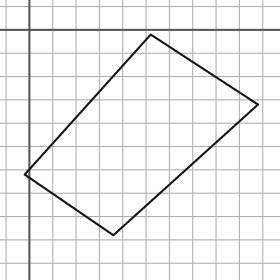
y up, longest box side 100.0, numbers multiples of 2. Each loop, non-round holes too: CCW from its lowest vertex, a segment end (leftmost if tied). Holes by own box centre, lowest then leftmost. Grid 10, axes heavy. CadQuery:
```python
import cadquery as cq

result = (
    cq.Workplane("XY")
    .moveTo(36.0, -88.0)
    .lineTo(98.0, -32.0)
    .lineTo(52.0, -2.0)
    .lineTo(-2.0, -62.0)
    .close()
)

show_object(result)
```